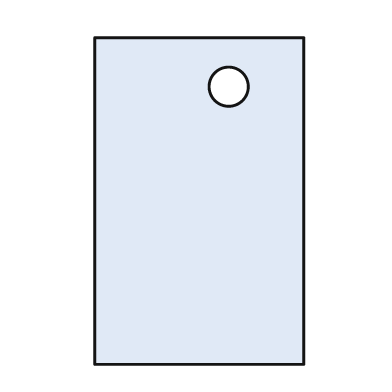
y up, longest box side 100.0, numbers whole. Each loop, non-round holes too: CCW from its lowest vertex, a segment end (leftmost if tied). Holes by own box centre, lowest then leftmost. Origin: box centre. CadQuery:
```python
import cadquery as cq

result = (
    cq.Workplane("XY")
    .moveTo(-32.0, -50.0)
    .lineTo(32.0, -50.0)
    .lineTo(32.0, 50.0)
    .lineTo(-32.0, 50.0)
    .close()
    .moveTo(9.0, 35.0)
    .circle(6.0)
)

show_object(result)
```